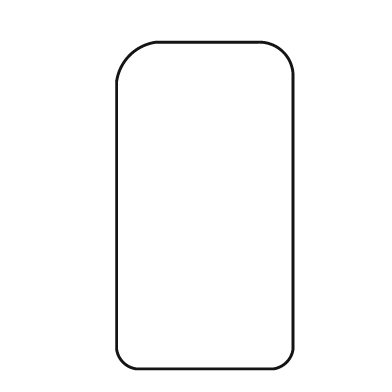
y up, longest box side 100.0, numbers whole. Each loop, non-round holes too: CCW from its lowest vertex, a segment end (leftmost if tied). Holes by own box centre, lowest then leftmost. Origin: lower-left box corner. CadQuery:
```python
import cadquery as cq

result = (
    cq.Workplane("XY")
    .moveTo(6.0, 0.0)
    .lineTo(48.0, 0.0)
    .threePointArc((52.0, 2.0), (54.0, 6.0))
    .lineTo(54.0, 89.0)
    .threePointArc((51.0, 97.0), (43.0, 100.0))
    .lineTo(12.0, 100.0)
    .threePointArc((4.0, 96.0), (0.0, 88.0))
    .lineTo(0.0, 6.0)
    .threePointArc((2.0, 2.0), (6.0, 0.0))
    .close()
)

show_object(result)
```